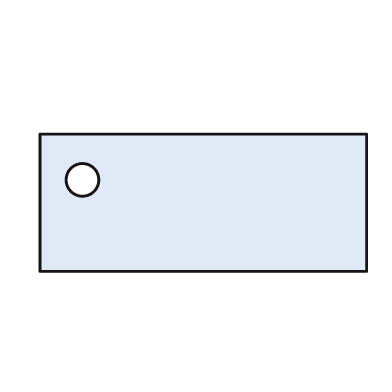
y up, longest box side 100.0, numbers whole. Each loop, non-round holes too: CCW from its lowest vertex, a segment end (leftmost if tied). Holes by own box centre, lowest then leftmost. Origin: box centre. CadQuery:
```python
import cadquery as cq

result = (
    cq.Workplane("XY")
    .moveTo(-50.0, -21.0)
    .lineTo(50.0, -21.0)
    .lineTo(50.0, 21.0)
    .lineTo(-50.0, 21.0)
    .close()
    .moveTo(-37.0, 7.0)
    .circle(5.0)
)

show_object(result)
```